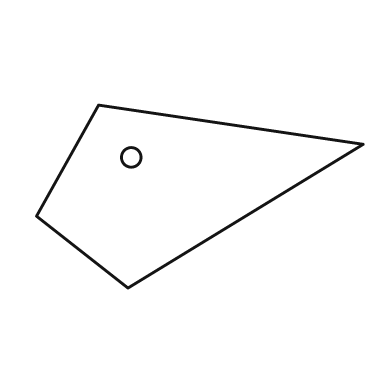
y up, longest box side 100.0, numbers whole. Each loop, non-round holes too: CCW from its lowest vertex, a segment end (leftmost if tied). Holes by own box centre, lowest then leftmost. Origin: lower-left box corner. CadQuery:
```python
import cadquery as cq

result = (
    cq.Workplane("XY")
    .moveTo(28.0, 0.0)
    .lineTo(100.0, 44.0)
    .lineTo(19.0, 56.0)
    .lineTo(0.0, 22.0)
    .close()
    .moveTo(29.0, 40.0)
    .circle(3.0)
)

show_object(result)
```